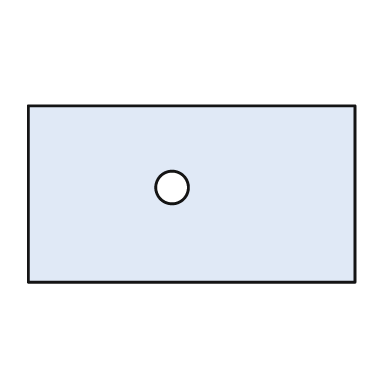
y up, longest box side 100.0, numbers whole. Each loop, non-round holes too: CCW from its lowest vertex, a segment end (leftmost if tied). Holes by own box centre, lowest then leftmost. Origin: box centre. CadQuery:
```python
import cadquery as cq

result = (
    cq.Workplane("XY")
    .moveTo(-50.0, -27.0)
    .lineTo(50.0, -27.0)
    .lineTo(50.0, 27.0)
    .lineTo(-50.0, 27.0)
    .close()
    .moveTo(-6.0, 2.0)
    .circle(5.0)
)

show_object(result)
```